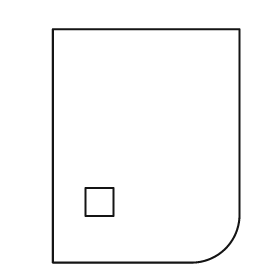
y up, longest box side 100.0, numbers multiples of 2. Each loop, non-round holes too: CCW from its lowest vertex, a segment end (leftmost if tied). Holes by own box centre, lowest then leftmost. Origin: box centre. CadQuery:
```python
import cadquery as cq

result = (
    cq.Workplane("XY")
    .moveTo(-40.0, -50.0)
    .lineTo(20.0, -50.0)
    .threePointArc((34.0, -44.0), (40.0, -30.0))
    .lineTo(40.0, 50.0)
    .lineTo(-40.0, 50.0)
    .close()
    .moveTo(-26.0, -30.0)
    .lineTo(-14.0, -30.0)
    .lineTo(-14.0, -18.0)
    .lineTo(-26.0, -18.0)
    .close()
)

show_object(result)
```